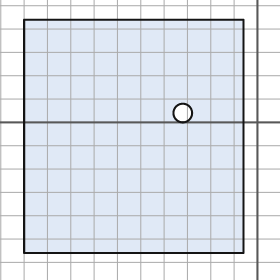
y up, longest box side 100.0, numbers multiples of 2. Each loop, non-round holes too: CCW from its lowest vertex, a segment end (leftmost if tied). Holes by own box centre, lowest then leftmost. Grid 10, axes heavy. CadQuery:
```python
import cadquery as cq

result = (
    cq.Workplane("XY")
    .moveTo(-100.0, -56.0)
    .lineTo(-6.0, -56.0)
    .lineTo(-6.0, 44.0)
    .lineTo(-100.0, 44.0)
    .close()
    .moveTo(-32.0, 4.0)
    .circle(4.0)
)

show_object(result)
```